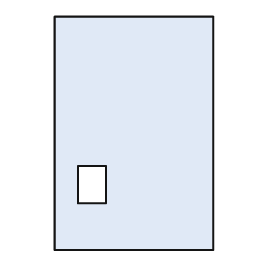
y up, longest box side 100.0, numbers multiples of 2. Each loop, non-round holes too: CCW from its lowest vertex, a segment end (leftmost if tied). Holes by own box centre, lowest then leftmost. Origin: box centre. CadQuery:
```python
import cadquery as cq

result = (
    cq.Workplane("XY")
    .moveTo(-34.0, -50.0)
    .lineTo(34.0, -50.0)
    .lineTo(34.0, 50.0)
    .lineTo(-34.0, 50.0)
    .close()
    .moveTo(-24.0, -30.0)
    .lineTo(-12.0, -30.0)
    .lineTo(-12.0, -14.0)
    .lineTo(-24.0, -14.0)
    .close()
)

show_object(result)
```